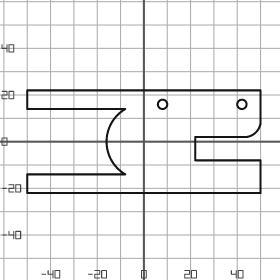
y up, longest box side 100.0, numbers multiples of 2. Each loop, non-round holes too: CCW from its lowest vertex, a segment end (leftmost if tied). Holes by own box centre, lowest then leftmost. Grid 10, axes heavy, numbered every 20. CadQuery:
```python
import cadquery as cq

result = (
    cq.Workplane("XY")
    .moveTo(-50.0, -22.0)
    .lineTo(50.0, -22.0)
    .lineTo(50.0, -8.0)
    .lineTo(22.0, -8.0)
    .lineTo(22.0, 2.0)
    .lineTo(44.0, 2.0)
    .threePointArc((48.0, 4.0), (50.0, 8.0))
    .lineTo(50.0, 22.0)
    .lineTo(-50.0, 22.0)
    .lineTo(-50.0, 14.0)
    .lineTo(-8.0, 14.0)
    .threePointArc((-16.0, 0.0), (-8.0, -14.0))
    .lineTo(-50.0, -14.0)
    .close()
    .moveTo(8.0, 16.0)
    .circle(2.0)
    .moveTo(42.0, 16.0)
    .circle(2.0)
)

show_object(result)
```